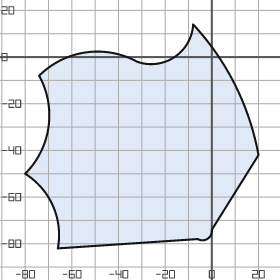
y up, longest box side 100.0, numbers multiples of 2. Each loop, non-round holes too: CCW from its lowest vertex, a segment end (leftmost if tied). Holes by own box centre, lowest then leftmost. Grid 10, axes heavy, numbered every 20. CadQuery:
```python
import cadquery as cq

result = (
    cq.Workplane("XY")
    .moveTo(-66.0, -82.0)
    .lineTo(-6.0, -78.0)
    .threePointArc((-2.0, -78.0), (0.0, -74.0))
    .lineTo(20.0, -42.0)
    .threePointArc((10.0, -12.0), (-8.0, 14.0))
    .threePointArc((-16.0, 0.0), (-32.0, -2.0))
    .threePointArc((-54.0, 2.0), (-74.0, -8.0))
    .threePointArc((-70.0, -30.0), (-80.0, -50.0))
    .threePointArc((-68.0, -64.0), (-66.0, -82.0))
    .close()
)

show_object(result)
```